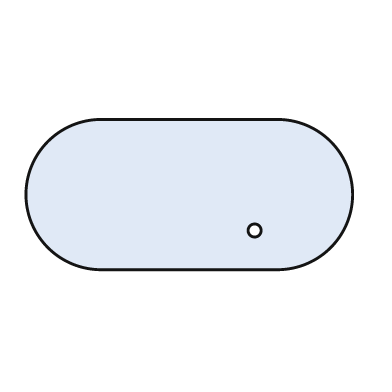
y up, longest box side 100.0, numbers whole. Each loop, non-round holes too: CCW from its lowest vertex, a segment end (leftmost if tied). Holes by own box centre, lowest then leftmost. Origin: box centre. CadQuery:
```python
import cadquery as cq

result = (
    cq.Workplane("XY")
    .moveTo(-27.0, -23.0)
    .lineTo(27.0, -23.0)
    .threePointArc((50.0, 0.0), (27.0, 23.0))
    .lineTo(-27.0, 23.0)
    .threePointArc((-50.0, 0.0), (-27.0, -23.0))
    .close()
    .moveTo(20.0, -11.0)
    .circle(2.0)
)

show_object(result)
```